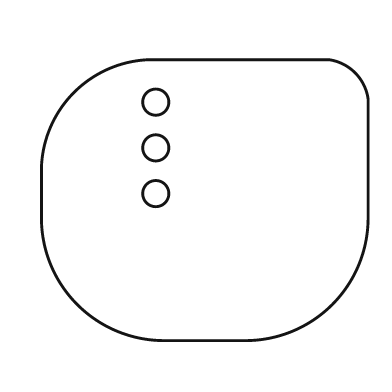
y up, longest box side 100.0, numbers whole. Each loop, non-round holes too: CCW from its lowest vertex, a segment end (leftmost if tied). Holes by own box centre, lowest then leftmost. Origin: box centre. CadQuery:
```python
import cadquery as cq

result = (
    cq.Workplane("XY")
    .moveTo(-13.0, -43.0)
    .lineTo(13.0, -43.0)
    .threePointArc((39.0, -32.0), (50.0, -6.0))
    .lineTo(50.0, 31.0)
    .threePointArc((46.0, 39.0), (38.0, 43.0))
    .lineTo(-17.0, 43.0)
    .threePointArc((-40.0, 33.0), (-50.0, 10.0))
    .lineTo(-50.0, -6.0)
    .threePointArc((-39.0, -32.0), (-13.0, -43.0))
    .close()
    .moveTo(-15.0, 2.0)
    .circle(4.0)
    .moveTo(-15.0, 16.0)
    .circle(4.0)
    .moveTo(-15.0, 30.0)
    .circle(4.0)
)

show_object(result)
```